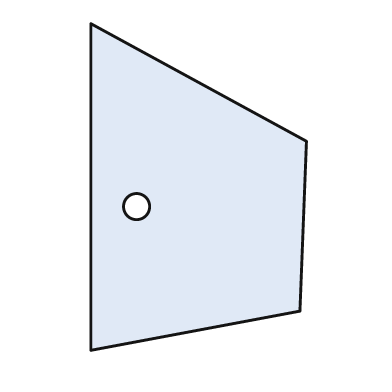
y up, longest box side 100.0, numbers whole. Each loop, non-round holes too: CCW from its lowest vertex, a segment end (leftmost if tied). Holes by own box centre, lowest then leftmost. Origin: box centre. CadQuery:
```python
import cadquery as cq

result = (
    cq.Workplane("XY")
    .moveTo(-33.0, -50.0)
    .lineTo(31.0, -38.0)
    .lineTo(33.0, 14.0)
    .lineTo(-33.0, 50.0)
    .close()
    .moveTo(-19.0, -6.0)
    .circle(4.0)
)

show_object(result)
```